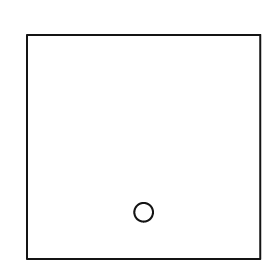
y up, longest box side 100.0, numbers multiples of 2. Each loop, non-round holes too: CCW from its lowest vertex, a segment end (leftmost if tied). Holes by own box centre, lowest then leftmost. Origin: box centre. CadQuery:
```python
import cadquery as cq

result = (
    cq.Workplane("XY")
    .moveTo(-50.0, -48.0)
    .lineTo(50.0, -48.0)
    .lineTo(50.0, 48.0)
    .lineTo(-50.0, 48.0)
    .close()
    .moveTo(0.0, -28.0)
    .circle(4.0)
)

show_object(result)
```